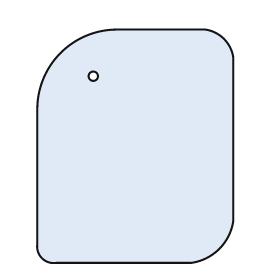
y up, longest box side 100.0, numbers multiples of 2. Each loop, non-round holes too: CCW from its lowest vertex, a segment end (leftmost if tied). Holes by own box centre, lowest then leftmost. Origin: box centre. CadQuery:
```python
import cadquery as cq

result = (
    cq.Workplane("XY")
    .moveTo(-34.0, -50.0)
    .lineTo(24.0, -50.0)
    .threePointArc((36.0, -44.0), (42.0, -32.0))
    .lineTo(42.0, 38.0)
    .threePointArc((38.0, 46.0), (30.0, 50.0))
    .lineTo(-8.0, 50.0)
    .threePointArc((-32.0, 40.0), (-42.0, 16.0))
    .lineTo(-42.0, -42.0)
    .threePointArc((-40.0, -48.0), (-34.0, -50.0))
    .close()
    .moveTo(-18.0, 30.0)
    .circle(2.0)
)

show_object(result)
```